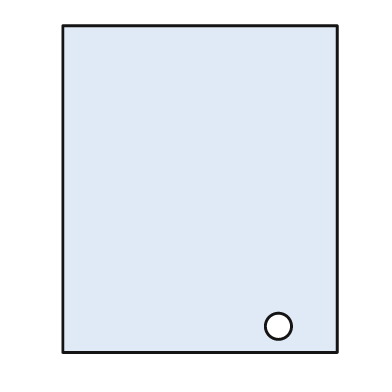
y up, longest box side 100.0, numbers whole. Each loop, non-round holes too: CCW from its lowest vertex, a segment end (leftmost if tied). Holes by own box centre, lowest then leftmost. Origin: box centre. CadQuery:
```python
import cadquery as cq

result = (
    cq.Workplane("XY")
    .moveTo(-42.0, -50.0)
    .lineTo(42.0, -50.0)
    .lineTo(42.0, 50.0)
    .lineTo(-42.0, 50.0)
    .close()
    .moveTo(24.0, -42.0)
    .circle(4.0)
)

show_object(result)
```